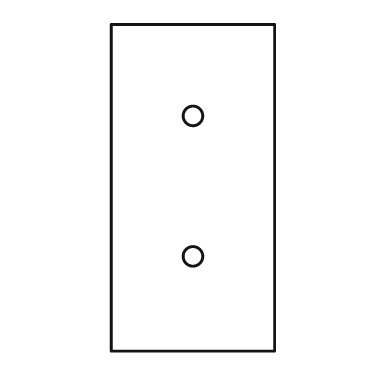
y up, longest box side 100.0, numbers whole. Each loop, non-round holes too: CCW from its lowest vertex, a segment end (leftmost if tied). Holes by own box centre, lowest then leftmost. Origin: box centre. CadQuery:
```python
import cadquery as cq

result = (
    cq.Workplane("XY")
    .moveTo(-25.0, -50.0)
    .lineTo(25.0, -50.0)
    .lineTo(25.0, 50.0)
    .lineTo(-25.0, 50.0)
    .close()
    .moveTo(0.0, -21.0)
    .circle(3.0)
    .moveTo(0.0, 22.0)
    .circle(3.0)
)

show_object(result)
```